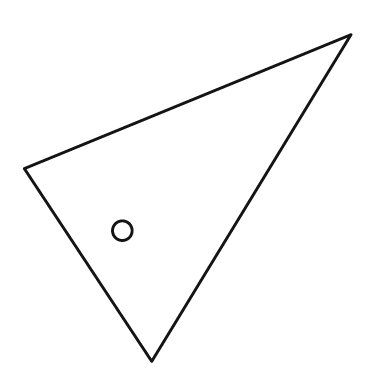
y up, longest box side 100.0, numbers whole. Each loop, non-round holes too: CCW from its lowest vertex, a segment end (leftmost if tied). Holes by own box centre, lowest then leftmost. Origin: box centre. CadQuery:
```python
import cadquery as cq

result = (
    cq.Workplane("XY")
    .moveTo(-11.0, -50.0)
    .lineTo(50.0, 50.0)
    .lineTo(-50.0, 9.0)
    .close()
    .moveTo(-20.0, -10.0)
    .circle(3.0)
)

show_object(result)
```